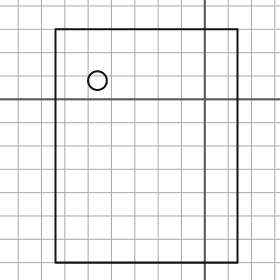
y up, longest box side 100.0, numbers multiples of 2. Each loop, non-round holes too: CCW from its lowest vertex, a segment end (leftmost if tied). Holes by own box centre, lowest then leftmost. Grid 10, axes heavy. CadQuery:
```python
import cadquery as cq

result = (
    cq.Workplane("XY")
    .moveTo(-64.0, -70.0)
    .lineTo(14.0, -70.0)
    .lineTo(14.0, 30.0)
    .lineTo(-64.0, 30.0)
    .close()
    .moveTo(-46.0, 8.0)
    .circle(4.0)
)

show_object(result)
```